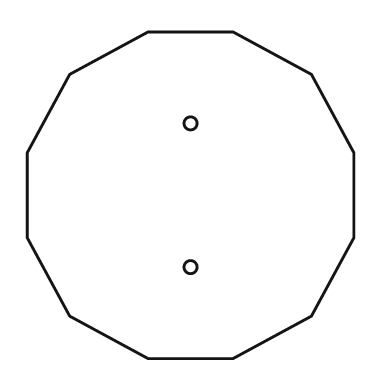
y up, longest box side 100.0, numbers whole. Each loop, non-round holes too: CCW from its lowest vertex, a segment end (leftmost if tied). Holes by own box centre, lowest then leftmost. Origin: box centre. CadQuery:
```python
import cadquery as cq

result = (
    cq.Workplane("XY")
    .moveTo(-13.0, -50.0)
    .lineTo(13.0, -50.0)
    .lineTo(37.0, -37.0)
    .lineTo(50.0, -13.0)
    .lineTo(50.0, 13.0)
    .lineTo(37.0, 37.0)
    .lineTo(13.0, 50.0)
    .lineTo(-13.0, 50.0)
    .lineTo(-37.0, 37.0)
    .lineTo(-50.0, 13.0)
    .lineTo(-50.0, -13.0)
    .lineTo(-37.0, -37.0)
    .close()
    .moveTo(0.0, -22.0)
    .circle(2.0)
    .moveTo(0.0, 22.0)
    .circle(2.0)
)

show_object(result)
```